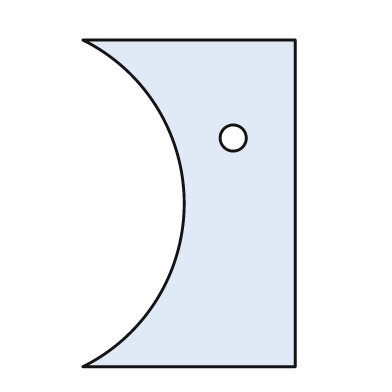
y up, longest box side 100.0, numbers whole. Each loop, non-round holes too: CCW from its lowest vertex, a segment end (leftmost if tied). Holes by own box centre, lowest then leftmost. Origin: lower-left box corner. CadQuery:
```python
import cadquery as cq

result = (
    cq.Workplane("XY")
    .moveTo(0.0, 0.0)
    .lineTo(65.0, 0.0)
    .lineTo(65.0, 100.0)
    .lineTo(0.0, 100.0)
    .threePointArc((31.0, 50.0), (0.0, 0.0))
    .close()
    .moveTo(46.0, 70.0)
    .circle(4.0)
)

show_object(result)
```